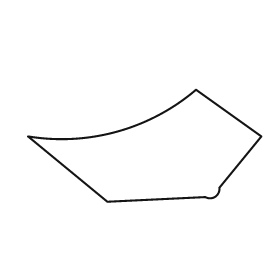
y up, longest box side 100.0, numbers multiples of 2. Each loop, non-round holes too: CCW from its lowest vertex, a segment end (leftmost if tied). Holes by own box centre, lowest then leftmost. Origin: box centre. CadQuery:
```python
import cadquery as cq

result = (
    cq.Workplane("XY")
    .moveTo(-16.0, -24.0)
    .lineTo(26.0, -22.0)
    .threePointArc((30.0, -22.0), (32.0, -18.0))
    .lineTo(50.0, 4.0)
    .lineTo(22.0, 24.0)
    .threePointArc((-12.0, 6.0), (-50.0, 4.0))
    .close()
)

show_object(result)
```